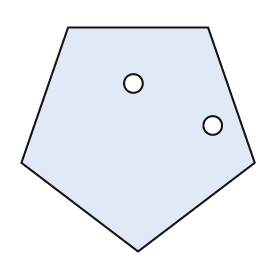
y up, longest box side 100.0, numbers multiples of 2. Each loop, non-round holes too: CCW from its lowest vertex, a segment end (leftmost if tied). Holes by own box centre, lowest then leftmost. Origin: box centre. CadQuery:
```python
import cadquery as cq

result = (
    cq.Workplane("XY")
    .moveTo(0.0, -48.0)
    .lineTo(50.0, -10.0)
    .lineTo(30.0, 48.0)
    .lineTo(-30.0, 48.0)
    .lineTo(-50.0, -10.0)
    .close()
    .moveTo(32.0, 6.0)
    .circle(4.0)
    .moveTo(-2.0, 24.0)
    .circle(4.0)
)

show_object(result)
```